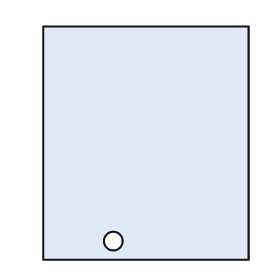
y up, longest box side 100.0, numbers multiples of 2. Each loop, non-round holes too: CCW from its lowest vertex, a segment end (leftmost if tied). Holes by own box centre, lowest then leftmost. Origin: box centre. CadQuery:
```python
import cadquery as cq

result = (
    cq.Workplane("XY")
    .moveTo(-44.0, -50.0)
    .lineTo(44.0, -50.0)
    .lineTo(44.0, 50.0)
    .lineTo(-44.0, 50.0)
    .close()
    .moveTo(-14.0, -42.0)
    .circle(4.0)
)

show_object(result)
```